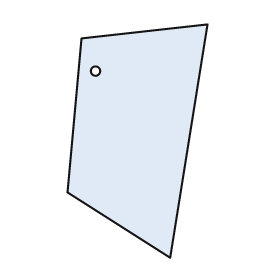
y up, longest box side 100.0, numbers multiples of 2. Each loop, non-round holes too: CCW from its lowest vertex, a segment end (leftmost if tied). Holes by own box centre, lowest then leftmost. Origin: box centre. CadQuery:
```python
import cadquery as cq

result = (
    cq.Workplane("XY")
    .moveTo(14.0, -50.0)
    .lineTo(30.0, 50.0)
    .lineTo(-24.0, 44.0)
    .lineTo(-30.0, -22.0)
    .close()
    .moveTo(-18.0, 30.0)
    .circle(2.0)
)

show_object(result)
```